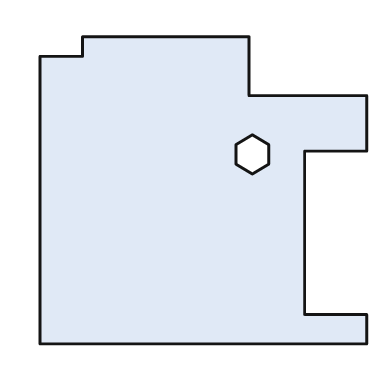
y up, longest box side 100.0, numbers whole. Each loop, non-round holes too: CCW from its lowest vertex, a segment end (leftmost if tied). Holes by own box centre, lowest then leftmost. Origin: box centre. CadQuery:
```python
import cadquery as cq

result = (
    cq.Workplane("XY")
    .moveTo(-50.0, -47.0)
    .lineTo(50.0, -47.0)
    .lineTo(50.0, -38.0)
    .lineTo(31.0, -38.0)
    .lineTo(31.0, 12.0)
    .lineTo(50.0, 12.0)
    .lineTo(50.0, 29.0)
    .lineTo(14.0, 29.0)
    .lineTo(14.0, 47.0)
    .lineTo(-37.0, 47.0)
    .lineTo(-37.0, 41.0)
    .lineTo(-50.0, 41.0)
    .close()
    .moveTo(15.0, 5.0)
    .lineTo(20.0, 8.0)
    .lineTo(20.0, 14.0)
    .lineTo(15.0, 17.0)
    .lineTo(10.0, 14.0)
    .lineTo(10.0, 8.0)
    .close()
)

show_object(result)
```